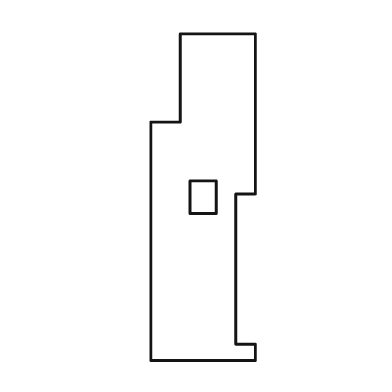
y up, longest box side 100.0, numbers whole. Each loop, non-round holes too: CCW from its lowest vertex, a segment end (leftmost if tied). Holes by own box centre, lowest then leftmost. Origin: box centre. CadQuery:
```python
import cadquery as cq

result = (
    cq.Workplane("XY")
    .moveTo(-16.0, -50.0)
    .lineTo(16.0, -50.0)
    .lineTo(16.0, -45.0)
    .lineTo(10.0, -45.0)
    .lineTo(10.0, 1.0)
    .lineTo(16.0, 1.0)
    .lineTo(16.0, 50.0)
    .lineTo(-7.0, 50.0)
    .lineTo(-7.0, 23.0)
    .lineTo(-16.0, 23.0)
    .close()
    .moveTo(-4.0, -5.0)
    .lineTo(4.0, -5.0)
    .lineTo(4.0, 5.0)
    .lineTo(-4.0, 5.0)
    .close()
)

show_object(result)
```